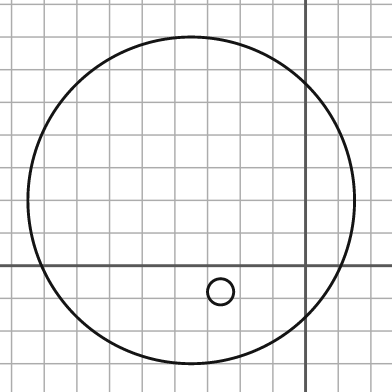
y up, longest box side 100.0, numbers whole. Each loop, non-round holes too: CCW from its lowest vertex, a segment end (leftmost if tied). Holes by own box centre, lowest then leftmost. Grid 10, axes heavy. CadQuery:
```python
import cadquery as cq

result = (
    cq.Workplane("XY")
    .moveTo(-35.0, 20.0)
    .circle(50.0)
    .moveTo(-26.0, -8.0)
    .circle(4.0)
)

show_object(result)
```